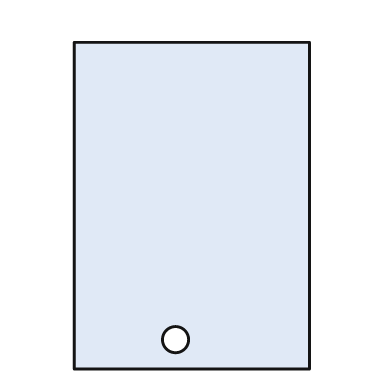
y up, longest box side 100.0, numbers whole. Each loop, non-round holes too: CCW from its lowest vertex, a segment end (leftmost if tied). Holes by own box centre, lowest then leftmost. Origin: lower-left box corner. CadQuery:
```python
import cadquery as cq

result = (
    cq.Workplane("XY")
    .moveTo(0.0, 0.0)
    .lineTo(72.0, 0.0)
    .lineTo(72.0, 100.0)
    .lineTo(0.0, 100.0)
    .close()
    .moveTo(31.0, 9.0)
    .circle(4.0)
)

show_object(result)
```